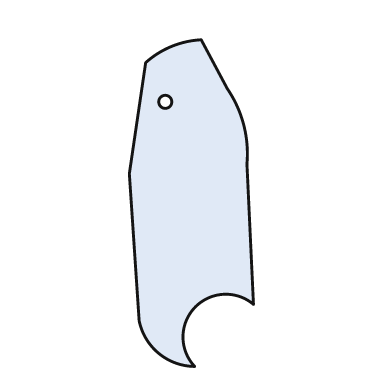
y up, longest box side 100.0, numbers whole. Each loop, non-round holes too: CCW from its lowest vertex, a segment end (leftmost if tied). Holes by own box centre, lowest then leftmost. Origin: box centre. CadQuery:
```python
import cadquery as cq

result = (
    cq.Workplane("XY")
    .moveTo(1.0, -50.0)
    .threePointArc((1.0, -32.0), (19.0, -31.0))
    .lineTo(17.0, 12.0)
    .threePointArc((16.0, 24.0), (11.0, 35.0))
    .lineTo(3.0, 50.0)
    .threePointArc((-6.0, 48.0), (-14.0, 43.0))
    .lineTo(-19.0, 9.0)
    .lineTo(-16.0, -36.0)
    .threePointArc((-10.0, -46.0), (1.0, -50.0))
    .close()
    .moveTo(-8.0, 31.0)
    .circle(2.0)
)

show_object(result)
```